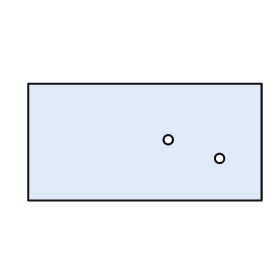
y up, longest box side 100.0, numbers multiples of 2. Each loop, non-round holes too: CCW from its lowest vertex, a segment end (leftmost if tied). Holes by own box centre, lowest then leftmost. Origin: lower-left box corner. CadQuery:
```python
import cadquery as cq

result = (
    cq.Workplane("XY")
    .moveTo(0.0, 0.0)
    .lineTo(100.0, 0.0)
    .lineTo(100.0, 50.0)
    .lineTo(0.0, 50.0)
    .close()
    .moveTo(82.0, 18.0)
    .circle(2.0)
    .moveTo(60.0, 26.0)
    .circle(2.0)
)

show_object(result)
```